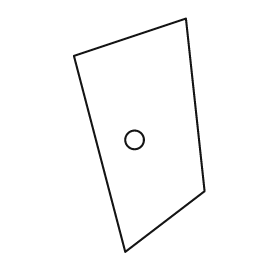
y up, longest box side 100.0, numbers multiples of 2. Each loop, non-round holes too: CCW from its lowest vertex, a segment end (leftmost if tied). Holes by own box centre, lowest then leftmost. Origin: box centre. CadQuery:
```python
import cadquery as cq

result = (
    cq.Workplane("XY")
    .moveTo(-6.0, -50.0)
    .lineTo(28.0, -24.0)
    .lineTo(20.0, 50.0)
    .lineTo(-28.0, 34.0)
    .close()
    .moveTo(-2.0, -2.0)
    .circle(4.0)
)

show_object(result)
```